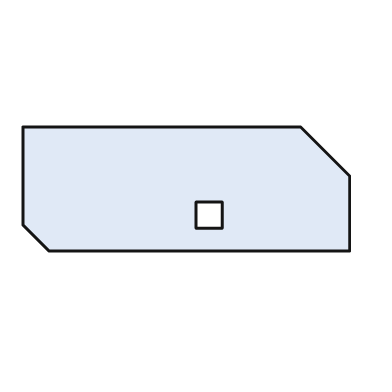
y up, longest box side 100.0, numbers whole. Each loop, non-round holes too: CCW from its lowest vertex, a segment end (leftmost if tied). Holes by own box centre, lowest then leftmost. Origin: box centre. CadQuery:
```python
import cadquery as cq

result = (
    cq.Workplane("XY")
    .moveTo(-42.0, -19.0)
    .lineTo(50.0, -19.0)
    .lineTo(50.0, 4.0)
    .lineTo(35.0, 19.0)
    .lineTo(-50.0, 19.0)
    .lineTo(-50.0, -11.0)
    .close()
    .moveTo(3.0, -12.0)
    .lineTo(11.0, -12.0)
    .lineTo(11.0, -4.0)
    .lineTo(3.0, -4.0)
    .close()
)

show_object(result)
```